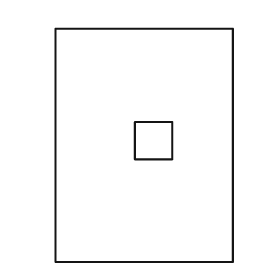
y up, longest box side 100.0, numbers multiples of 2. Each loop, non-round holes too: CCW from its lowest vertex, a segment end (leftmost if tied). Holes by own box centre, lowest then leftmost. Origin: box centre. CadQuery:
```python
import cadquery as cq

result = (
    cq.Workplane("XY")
    .moveTo(-38.0, -50.0)
    .lineTo(38.0, -50.0)
    .lineTo(38.0, 50.0)
    .lineTo(-38.0, 50.0)
    .close()
    .moveTo(-4.0, -6.0)
    .lineTo(12.0, -6.0)
    .lineTo(12.0, 10.0)
    .lineTo(-4.0, 10.0)
    .close()
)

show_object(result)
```